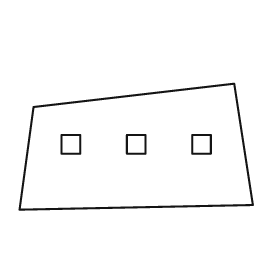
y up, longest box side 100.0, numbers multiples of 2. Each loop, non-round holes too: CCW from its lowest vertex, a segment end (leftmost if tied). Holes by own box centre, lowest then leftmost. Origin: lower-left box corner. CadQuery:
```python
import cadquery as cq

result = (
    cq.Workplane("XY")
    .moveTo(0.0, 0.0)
    .lineTo(100.0, 2.0)
    .lineTo(92.0, 54.0)
    .lineTo(6.0, 44.0)
    .close()
    .moveTo(18.0, 24.0)
    .lineTo(26.0, 24.0)
    .lineTo(26.0, 32.0)
    .lineTo(18.0, 32.0)
    .close()
    .moveTo(46.0, 24.0)
    .lineTo(54.0, 24.0)
    .lineTo(54.0, 32.0)
    .lineTo(46.0, 32.0)
    .close()
    .moveTo(74.0, 24.0)
    .lineTo(82.0, 24.0)
    .lineTo(82.0, 32.0)
    .lineTo(74.0, 32.0)
    .close()
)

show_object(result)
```